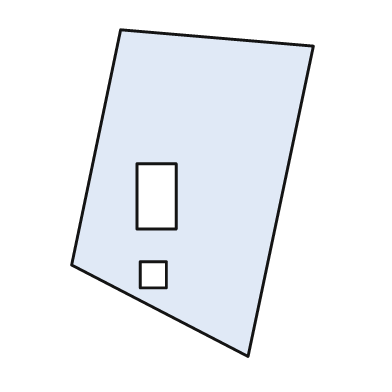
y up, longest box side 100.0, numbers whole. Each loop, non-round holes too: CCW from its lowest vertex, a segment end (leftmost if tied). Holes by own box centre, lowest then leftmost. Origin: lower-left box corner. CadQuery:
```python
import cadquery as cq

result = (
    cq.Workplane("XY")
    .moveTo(54.0, 0.0)
    .lineTo(74.0, 95.0)
    .lineTo(15.0, 100.0)
    .lineTo(0.0, 28.0)
    .close()
    .moveTo(21.0, 21.0)
    .lineTo(29.0, 21.0)
    .lineTo(29.0, 29.0)
    .lineTo(21.0, 29.0)
    .close()
    .moveTo(20.0, 39.0)
    .lineTo(32.0, 39.0)
    .lineTo(32.0, 59.0)
    .lineTo(20.0, 59.0)
    .close()
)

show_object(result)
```